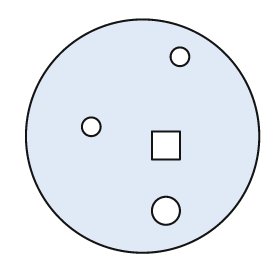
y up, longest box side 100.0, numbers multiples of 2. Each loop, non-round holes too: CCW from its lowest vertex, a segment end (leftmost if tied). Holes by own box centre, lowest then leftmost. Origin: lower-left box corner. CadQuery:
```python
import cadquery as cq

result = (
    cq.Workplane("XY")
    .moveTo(50.0, 50.0)
    .circle(50.0)
    .moveTo(60.0, 18.0)
    .circle(6.0)
    .moveTo(54.0, 40.0)
    .lineTo(66.0, 40.0)
    .lineTo(66.0, 52.0)
    .lineTo(54.0, 52.0)
    .close()
    .moveTo(28.0, 54.0)
    .circle(4.0)
    .moveTo(66.0, 84.0)
    .circle(4.0)
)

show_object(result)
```